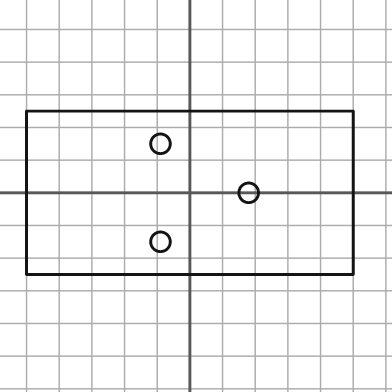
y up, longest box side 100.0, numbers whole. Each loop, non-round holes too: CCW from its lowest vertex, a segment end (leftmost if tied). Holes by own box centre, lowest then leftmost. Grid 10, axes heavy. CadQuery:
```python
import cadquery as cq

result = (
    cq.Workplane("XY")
    .moveTo(-50.0, -25.0)
    .lineTo(50.0, -25.0)
    .lineTo(50.0, 25.0)
    .lineTo(-50.0, 25.0)
    .close()
    .moveTo(-9.0, -15.0)
    .circle(3.0)
    .moveTo(18.0, 0.0)
    .circle(3.0)
    .moveTo(-9.0, 15.0)
    .circle(3.0)
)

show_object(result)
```